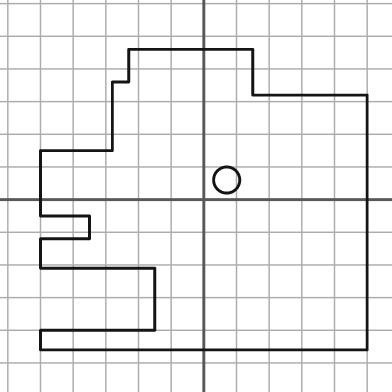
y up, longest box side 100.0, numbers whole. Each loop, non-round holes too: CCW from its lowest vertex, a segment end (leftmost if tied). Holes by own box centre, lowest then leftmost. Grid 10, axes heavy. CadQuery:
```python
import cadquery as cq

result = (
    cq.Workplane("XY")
    .moveTo(-50.0, -46.0)
    .lineTo(50.0, -46.0)
    .lineTo(50.0, 32.0)
    .lineTo(15.0, 32.0)
    .lineTo(15.0, 46.0)
    .lineTo(-23.0, 46.0)
    .lineTo(-23.0, 36.0)
    .lineTo(-28.0, 36.0)
    .lineTo(-28.0, 15.0)
    .lineTo(-50.0, 15.0)
    .lineTo(-50.0, -5.0)
    .lineTo(-35.0, -5.0)
    .lineTo(-35.0, -12.0)
    .lineTo(-50.0, -12.0)
    .lineTo(-50.0, -21.0)
    .lineTo(-15.0, -21.0)
    .lineTo(-15.0, -40.0)
    .lineTo(-50.0, -40.0)
    .close()
    .moveTo(7.0, 6.0)
    .circle(4.0)
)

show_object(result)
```